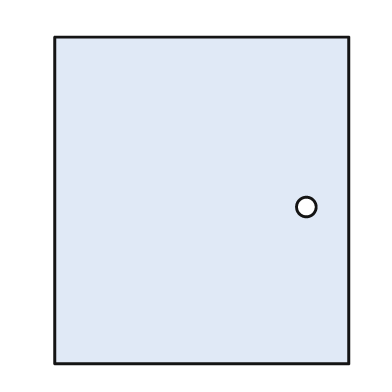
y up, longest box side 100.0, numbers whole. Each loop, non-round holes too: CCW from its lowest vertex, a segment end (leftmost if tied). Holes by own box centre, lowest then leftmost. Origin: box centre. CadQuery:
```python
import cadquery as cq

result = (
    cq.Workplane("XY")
    .moveTo(-45.0, -50.0)
    .lineTo(45.0, -50.0)
    .lineTo(45.0, 50.0)
    .lineTo(-45.0, 50.0)
    .close()
    .moveTo(32.0, -2.0)
    .circle(3.0)
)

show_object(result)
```